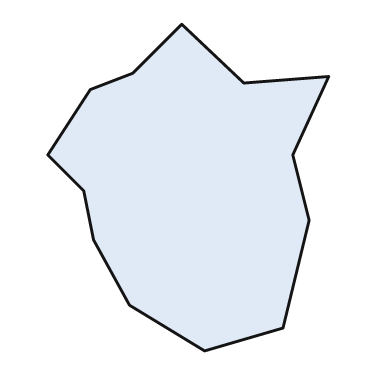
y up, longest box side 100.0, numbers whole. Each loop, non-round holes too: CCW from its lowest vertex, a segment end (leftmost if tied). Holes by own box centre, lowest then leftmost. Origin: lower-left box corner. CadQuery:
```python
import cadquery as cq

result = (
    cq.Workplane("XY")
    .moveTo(48.0, 0.0)
    .lineTo(72.0, 7.0)
    .lineTo(80.0, 40.0)
    .lineTo(75.0, 60.0)
    .lineTo(86.0, 84.0)
    .lineTo(60.0, 82.0)
    .lineTo(41.0, 100.0)
    .lineTo(26.0, 85.0)
    .lineTo(13.0, 80.0)
    .lineTo(0.0, 60.0)
    .lineTo(11.0, 49.0)
    .lineTo(14.0, 34.0)
    .lineTo(25.0, 14.0)
    .close()
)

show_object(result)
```